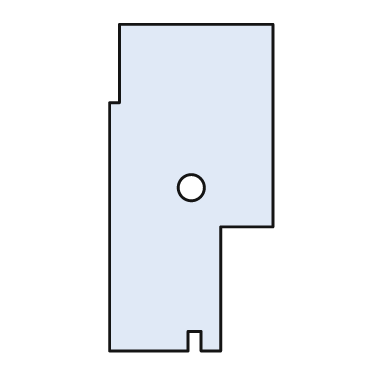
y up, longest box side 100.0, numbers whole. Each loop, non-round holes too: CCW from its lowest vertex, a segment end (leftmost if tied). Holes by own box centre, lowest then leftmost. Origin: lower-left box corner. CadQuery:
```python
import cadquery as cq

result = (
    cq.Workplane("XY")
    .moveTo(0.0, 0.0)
    .lineTo(24.0, 0.0)
    .lineTo(24.0, 6.0)
    .lineTo(28.0, 6.0)
    .lineTo(28.0, 0.0)
    .lineTo(34.0, 0.0)
    .lineTo(34.0, 38.0)
    .lineTo(50.0, 38.0)
    .lineTo(50.0, 100.0)
    .lineTo(3.0, 100.0)
    .lineTo(3.0, 76.0)
    .lineTo(0.0, 76.0)
    .close()
    .moveTo(25.0, 50.0)
    .circle(4.0)
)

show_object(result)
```